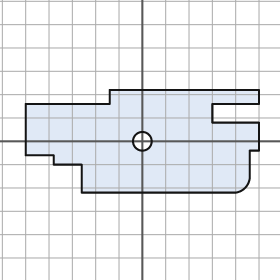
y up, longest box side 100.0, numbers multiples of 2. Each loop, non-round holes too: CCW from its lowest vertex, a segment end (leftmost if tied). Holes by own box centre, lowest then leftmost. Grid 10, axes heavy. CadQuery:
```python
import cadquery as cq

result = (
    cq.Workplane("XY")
    .moveTo(-26.0, -22.0)
    .lineTo(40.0, -22.0)
    .threePointArc((44.0, -20.0), (46.0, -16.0))
    .lineTo(46.0, -4.0)
    .lineTo(50.0, -4.0)
    .lineTo(50.0, 8.0)
    .lineTo(30.0, 8.0)
    .lineTo(30.0, 16.0)
    .lineTo(50.0, 16.0)
    .lineTo(50.0, 22.0)
    .lineTo(-14.0, 22.0)
    .lineTo(-14.0, 16.0)
    .lineTo(-50.0, 16.0)
    .lineTo(-50.0, -6.0)
    .lineTo(-38.0, -6.0)
    .lineTo(-38.0, -10.0)
    .lineTo(-26.0, -10.0)
    .close()
    .moveTo(0.0, 0.0)
    .circle(4.0)
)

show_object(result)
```